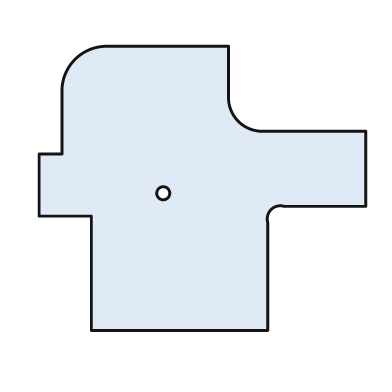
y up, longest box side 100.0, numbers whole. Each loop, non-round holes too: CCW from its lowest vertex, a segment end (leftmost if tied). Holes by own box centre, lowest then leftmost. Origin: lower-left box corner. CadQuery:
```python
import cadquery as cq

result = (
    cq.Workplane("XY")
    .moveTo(16.0, 0.0)
    .lineTo(70.0, 0.0)
    .lineTo(70.0, 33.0)
    .threePointArc((71.0, 37.0), (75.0, 38.0))
    .lineTo(100.0, 38.0)
    .lineTo(100.0, 61.0)
    .lineTo(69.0, 61.0)
    .threePointArc((61.0, 64.0), (58.0, 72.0))
    .lineTo(58.0, 87.0)
    .lineTo(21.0, 87.0)
    .threePointArc((11.0, 83.0), (7.0, 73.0))
    .lineTo(7.0, 54.0)
    .lineTo(0.0, 54.0)
    .lineTo(0.0, 35.0)
    .lineTo(16.0, 35.0)
    .close()
    .moveTo(38.0, 42.0)
    .circle(2.0)
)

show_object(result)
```